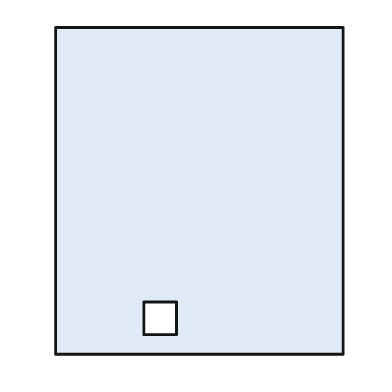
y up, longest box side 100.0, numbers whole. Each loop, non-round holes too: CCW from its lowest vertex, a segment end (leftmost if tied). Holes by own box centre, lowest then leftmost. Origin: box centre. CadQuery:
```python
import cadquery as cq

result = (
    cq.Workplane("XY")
    .moveTo(-44.0, -50.0)
    .lineTo(44.0, -50.0)
    .lineTo(44.0, 50.0)
    .lineTo(-44.0, 50.0)
    .close()
    .moveTo(-17.0, -44.0)
    .lineTo(-7.0, -44.0)
    .lineTo(-7.0, -34.0)
    .lineTo(-17.0, -34.0)
    .close()
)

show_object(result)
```